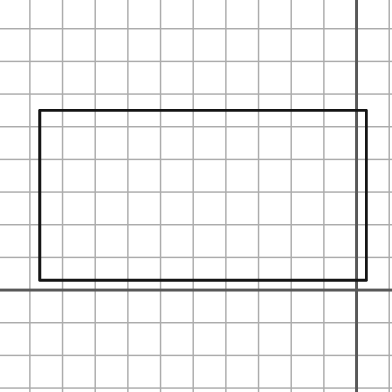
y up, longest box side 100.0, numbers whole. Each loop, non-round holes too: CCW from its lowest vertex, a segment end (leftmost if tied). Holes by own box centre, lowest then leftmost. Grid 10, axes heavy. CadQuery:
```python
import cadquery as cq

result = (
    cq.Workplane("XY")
    .moveTo(-97.0, 3.0)
    .lineTo(3.0, 3.0)
    .lineTo(3.0, 55.0)
    .lineTo(-97.0, 55.0)
    .close()
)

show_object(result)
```